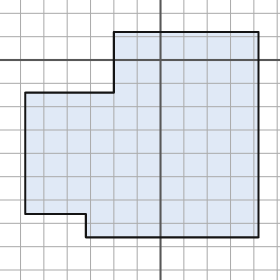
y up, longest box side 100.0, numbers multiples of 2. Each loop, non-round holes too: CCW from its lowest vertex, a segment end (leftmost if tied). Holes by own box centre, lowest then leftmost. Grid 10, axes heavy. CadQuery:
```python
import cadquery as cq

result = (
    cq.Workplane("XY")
    .moveTo(-32.0, -76.0)
    .lineTo(42.0, -76.0)
    .lineTo(42.0, 12.0)
    .lineTo(-20.0, 12.0)
    .lineTo(-20.0, -14.0)
    .lineTo(-58.0, -14.0)
    .lineTo(-58.0, -66.0)
    .lineTo(-32.0, -66.0)
    .close()
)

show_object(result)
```